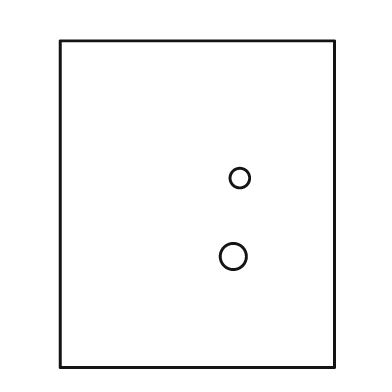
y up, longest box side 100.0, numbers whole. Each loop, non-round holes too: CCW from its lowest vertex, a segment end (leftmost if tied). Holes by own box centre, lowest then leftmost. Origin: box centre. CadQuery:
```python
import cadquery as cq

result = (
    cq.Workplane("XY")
    .moveTo(-42.0, -50.0)
    .lineTo(42.0, -50.0)
    .lineTo(42.0, 50.0)
    .lineTo(-42.0, 50.0)
    .close()
    .moveTo(11.0, -16.0)
    .circle(4.0)
    .moveTo(13.0, 8.0)
    .circle(3.0)
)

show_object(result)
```